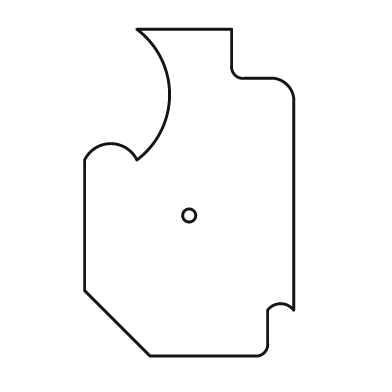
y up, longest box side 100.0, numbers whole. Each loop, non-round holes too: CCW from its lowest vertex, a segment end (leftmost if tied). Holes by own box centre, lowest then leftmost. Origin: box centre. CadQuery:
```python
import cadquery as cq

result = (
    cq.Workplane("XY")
    .moveTo(-12.0, -50.0)
    .lineTo(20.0, -50.0)
    .threePointArc((23.0, -49.0), (24.0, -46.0))
    .lineTo(24.0, -36.0)
    .threePointArc((28.0, -34.0), (32.0, -36.0))
    .lineTo(32.0, 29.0)
    .threePointArc((30.0, 33.0), (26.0, 35.0))
    .lineTo(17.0, 35.0)
    .threePointArc((14.0, 36.0), (13.0, 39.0))
    .lineTo(13.0, 50.0)
    .lineTo(-16.0, 50.0)
    .threePointArc((-6.0, 30.0), (-16.0, 10.0))
    .threePointArc((-24.0, 15.0), (-32.0, 10.0))
    .lineTo(-32.0, -30.0)
    .close()
    .moveTo(0.0, -7.0)
    .circle(2.0)
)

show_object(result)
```